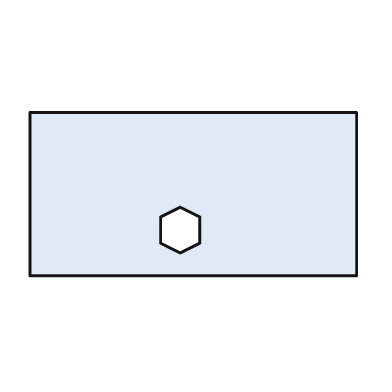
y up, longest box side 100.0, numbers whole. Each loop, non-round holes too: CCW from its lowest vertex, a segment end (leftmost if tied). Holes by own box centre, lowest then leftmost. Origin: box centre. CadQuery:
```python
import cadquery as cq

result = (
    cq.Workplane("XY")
    .moveTo(-50.0, -25.0)
    .lineTo(50.0, -25.0)
    .lineTo(50.0, 25.0)
    .lineTo(-50.0, 25.0)
    .close()
    .moveTo(-4.0, -18.0)
    .lineTo(2.0, -15.0)
    .lineTo(2.0, -7.0)
    .lineTo(-4.0, -4.0)
    .lineTo(-10.0, -7.0)
    .lineTo(-10.0, -15.0)
    .close()
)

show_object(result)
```